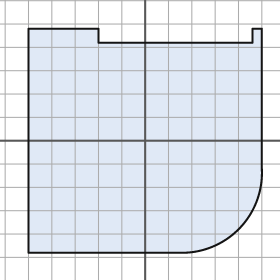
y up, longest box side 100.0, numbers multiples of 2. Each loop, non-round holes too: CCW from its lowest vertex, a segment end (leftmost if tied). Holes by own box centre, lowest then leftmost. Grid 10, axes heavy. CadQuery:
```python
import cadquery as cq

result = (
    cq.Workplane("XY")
    .moveTo(-50.0, -48.0)
    .lineTo(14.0, -48.0)
    .threePointArc((40.0, -38.0), (50.0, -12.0))
    .lineTo(50.0, 48.0)
    .lineTo(46.0, 48.0)
    .lineTo(46.0, 42.0)
    .lineTo(-20.0, 42.0)
    .lineTo(-20.0, 48.0)
    .lineTo(-50.0, 48.0)
    .close()
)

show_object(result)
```